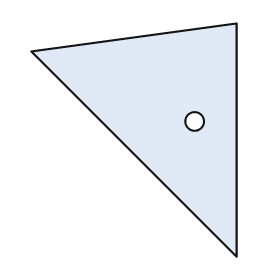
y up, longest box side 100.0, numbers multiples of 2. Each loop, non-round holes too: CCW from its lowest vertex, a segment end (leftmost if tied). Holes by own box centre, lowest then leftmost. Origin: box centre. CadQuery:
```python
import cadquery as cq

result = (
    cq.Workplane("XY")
    .moveTo(44.0, -50.0)
    .lineTo(44.0, 50.0)
    .lineTo(-44.0, 38.0)
    .close()
    .moveTo(26.0, 8.0)
    .circle(4.0)
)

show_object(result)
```